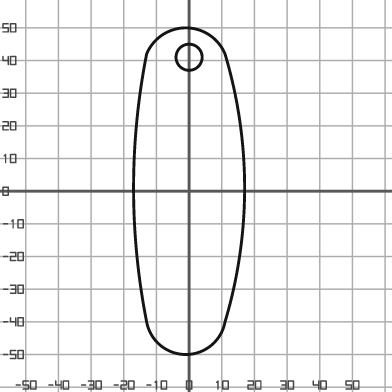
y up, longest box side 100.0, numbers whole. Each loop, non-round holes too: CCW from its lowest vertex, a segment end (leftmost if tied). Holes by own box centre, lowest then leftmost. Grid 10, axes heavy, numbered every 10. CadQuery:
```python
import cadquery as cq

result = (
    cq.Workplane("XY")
    .moveTo(-13.0, -40.0)
    .threePointArc((-1.0, -50.0), (11.0, -40.0))
    .threePointArc((17.0, 1.0), (11.0, 42.0))
    .threePointArc((-1.0, 50.0), (-13.0, 42.0))
    .threePointArc((-17.0, 1.0), (-13.0, -40.0))
    .close()
    .moveTo(0.0, 41.0)
    .circle(4.0)
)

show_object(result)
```